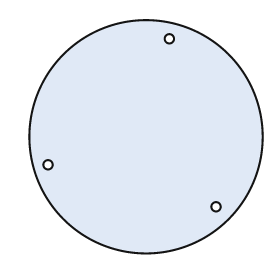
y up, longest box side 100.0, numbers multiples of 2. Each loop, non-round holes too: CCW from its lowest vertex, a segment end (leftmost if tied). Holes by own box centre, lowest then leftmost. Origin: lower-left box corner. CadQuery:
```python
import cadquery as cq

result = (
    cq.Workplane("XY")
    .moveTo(50.0, 50.0)
    .circle(50.0)
    .moveTo(80.0, 20.0)
    .circle(2.0)
    .moveTo(8.0, 38.0)
    .circle(2.0)
    .moveTo(60.0, 92.0)
    .circle(2.0)
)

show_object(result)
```